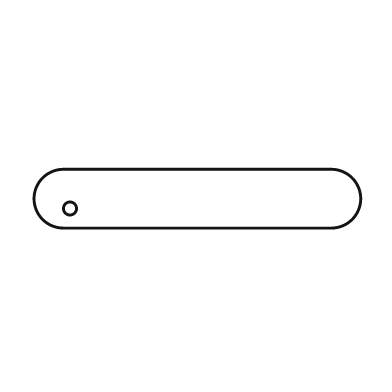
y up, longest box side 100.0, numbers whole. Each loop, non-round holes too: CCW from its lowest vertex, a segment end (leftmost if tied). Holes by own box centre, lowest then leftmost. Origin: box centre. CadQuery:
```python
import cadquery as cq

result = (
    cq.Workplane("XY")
    .moveTo(-41.0, -9.0)
    .lineTo(41.0, -9.0)
    .threePointArc((50.0, 0.0), (41.0, 9.0))
    .lineTo(-41.0, 9.0)
    .threePointArc((-50.0, 0.0), (-41.0, -9.0))
    .close()
    .moveTo(-39.0, -3.0)
    .circle(2.0)
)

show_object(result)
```